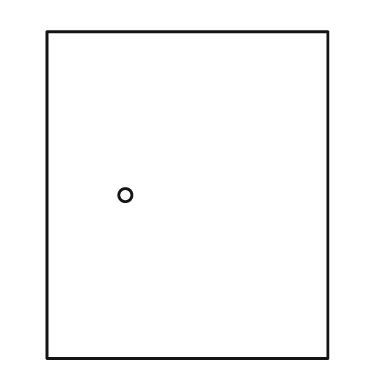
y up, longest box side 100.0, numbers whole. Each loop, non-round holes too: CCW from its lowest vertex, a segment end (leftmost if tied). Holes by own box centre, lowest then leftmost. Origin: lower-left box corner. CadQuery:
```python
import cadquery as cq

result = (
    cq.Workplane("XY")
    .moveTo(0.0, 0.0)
    .lineTo(86.0, 0.0)
    .lineTo(86.0, 100.0)
    .lineTo(0.0, 100.0)
    .close()
    .moveTo(24.0, 50.0)
    .circle(2.0)
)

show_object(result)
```